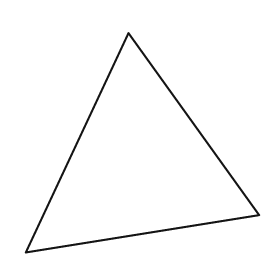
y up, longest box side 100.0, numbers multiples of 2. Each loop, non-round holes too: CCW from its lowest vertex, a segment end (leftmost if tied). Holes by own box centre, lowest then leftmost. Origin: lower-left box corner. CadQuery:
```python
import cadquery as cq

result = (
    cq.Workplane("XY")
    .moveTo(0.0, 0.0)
    .lineTo(100.0, 16.0)
    .lineTo(44.0, 94.0)
    .close()
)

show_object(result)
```